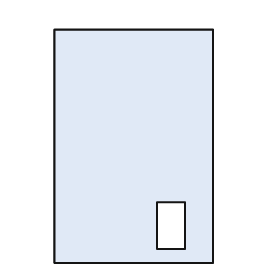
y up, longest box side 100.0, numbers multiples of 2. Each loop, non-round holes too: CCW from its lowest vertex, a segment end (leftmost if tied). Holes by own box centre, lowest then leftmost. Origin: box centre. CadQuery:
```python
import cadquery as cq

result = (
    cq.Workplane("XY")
    .moveTo(-34.0, -50.0)
    .lineTo(34.0, -50.0)
    .lineTo(34.0, 50.0)
    .lineTo(-34.0, 50.0)
    .close()
    .moveTo(10.0, -44.0)
    .lineTo(22.0, -44.0)
    .lineTo(22.0, -24.0)
    .lineTo(10.0, -24.0)
    .close()
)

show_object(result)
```